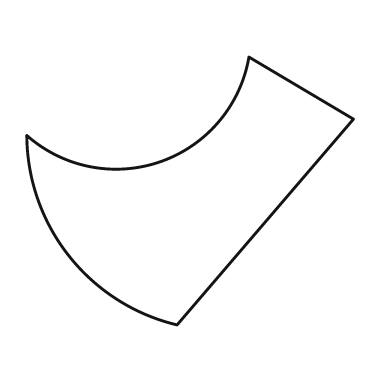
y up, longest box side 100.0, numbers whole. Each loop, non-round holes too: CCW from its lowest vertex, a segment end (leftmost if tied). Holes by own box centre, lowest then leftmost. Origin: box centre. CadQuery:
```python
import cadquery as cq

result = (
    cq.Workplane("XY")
    .moveTo(-4.0, -41.0)
    .lineTo(50.0, 22.0)
    .lineTo(18.0, 41.0)
    .threePointArc((-9.0, 9.0), (-50.0, 17.0))
    .threePointArc((-37.0, -20.0), (-4.0, -41.0))
    .close()
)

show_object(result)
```